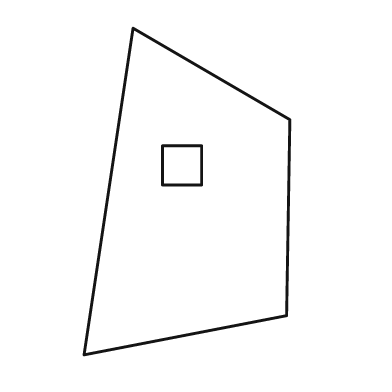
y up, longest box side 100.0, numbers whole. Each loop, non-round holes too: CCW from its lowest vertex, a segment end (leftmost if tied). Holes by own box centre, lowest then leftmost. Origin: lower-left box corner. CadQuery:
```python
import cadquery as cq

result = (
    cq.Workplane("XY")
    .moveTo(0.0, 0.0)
    .lineTo(62.0, 12.0)
    .lineTo(63.0, 72.0)
    .lineTo(15.0, 100.0)
    .close()
    .moveTo(24.0, 52.0)
    .lineTo(36.0, 52.0)
    .lineTo(36.0, 64.0)
    .lineTo(24.0, 64.0)
    .close()
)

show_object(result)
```